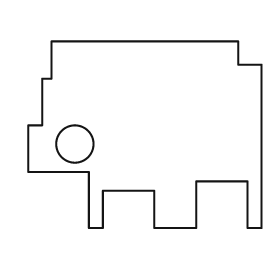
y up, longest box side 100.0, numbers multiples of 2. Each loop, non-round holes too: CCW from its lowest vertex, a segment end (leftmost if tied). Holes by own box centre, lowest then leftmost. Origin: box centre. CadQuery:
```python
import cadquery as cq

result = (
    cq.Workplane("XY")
    .moveTo(-24.0, -40.0)
    .lineTo(-18.0, -40.0)
    .lineTo(-18.0, -24.0)
    .lineTo(4.0, -24.0)
    .lineTo(4.0, -40.0)
    .lineTo(22.0, -40.0)
    .lineTo(22.0, -20.0)
    .lineTo(44.0, -20.0)
    .lineTo(44.0, -40.0)
    .lineTo(50.0, -40.0)
    .lineTo(50.0, 30.0)
    .lineTo(40.0, 30.0)
    .lineTo(40.0, 40.0)
    .lineTo(-40.0, 40.0)
    .lineTo(-40.0, 24.0)
    .lineTo(-44.0, 24.0)
    .lineTo(-44.0, 4.0)
    .lineTo(-50.0, 4.0)
    .lineTo(-50.0, -16.0)
    .lineTo(-24.0, -16.0)
    .close()
    .moveTo(-30.0, -4.0)
    .circle(8.0)
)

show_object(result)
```